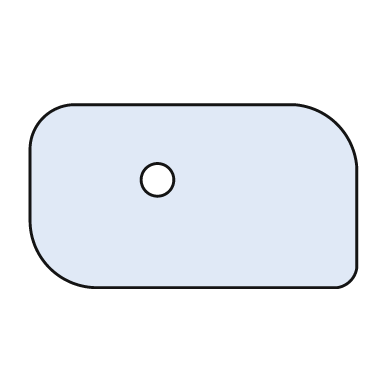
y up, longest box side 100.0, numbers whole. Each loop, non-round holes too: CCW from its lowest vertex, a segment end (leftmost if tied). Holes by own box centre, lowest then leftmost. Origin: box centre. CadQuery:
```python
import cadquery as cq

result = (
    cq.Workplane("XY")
    .moveTo(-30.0, -28.0)
    .lineTo(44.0, -28.0)
    .threePointArc((48.0, -26.0), (50.0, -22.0))
    .lineTo(50.0, 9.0)
    .threePointArc((44.0, 22.0), (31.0, 28.0))
    .lineTo(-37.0, 28.0)
    .threePointArc((-46.0, 24.0), (-50.0, 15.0))
    .lineTo(-50.0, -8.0)
    .threePointArc((-44.0, -22.0), (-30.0, -28.0))
    .close()
    .moveTo(-11.0, 5.0)
    .circle(5.0)
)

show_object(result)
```